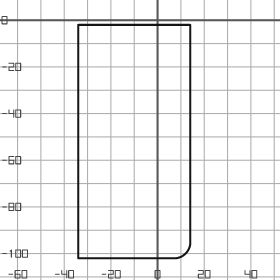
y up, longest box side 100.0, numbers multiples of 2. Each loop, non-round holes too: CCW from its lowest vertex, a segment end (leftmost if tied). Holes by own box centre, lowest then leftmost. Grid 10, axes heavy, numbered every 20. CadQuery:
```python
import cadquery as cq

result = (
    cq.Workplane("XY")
    .moveTo(-34.0, -102.0)
    .lineTo(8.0, -102.0)
    .threePointArc((12.0, -100.0), (14.0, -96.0))
    .lineTo(14.0, -2.0)
    .lineTo(-34.0, -2.0)
    .close()
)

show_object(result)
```